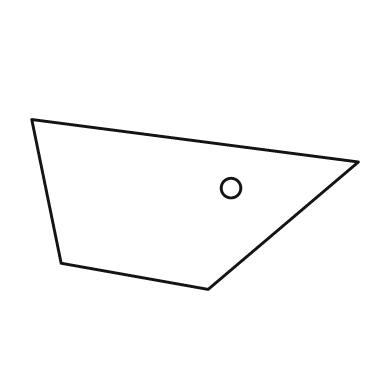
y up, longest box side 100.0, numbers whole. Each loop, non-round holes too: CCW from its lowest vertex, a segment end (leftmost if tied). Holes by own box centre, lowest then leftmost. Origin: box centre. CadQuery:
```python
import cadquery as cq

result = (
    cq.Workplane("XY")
    .moveTo(4.0, -26.0)
    .lineTo(50.0, 13.0)
    .lineTo(-50.0, 26.0)
    .lineTo(-41.0, -18.0)
    .close()
    .moveTo(11.0, 5.0)
    .circle(3.0)
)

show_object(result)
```